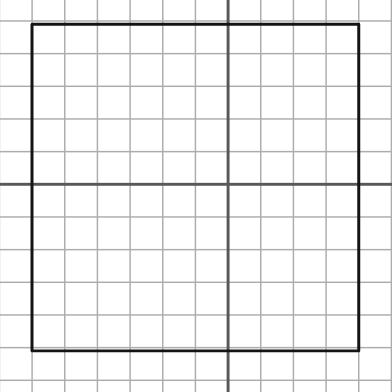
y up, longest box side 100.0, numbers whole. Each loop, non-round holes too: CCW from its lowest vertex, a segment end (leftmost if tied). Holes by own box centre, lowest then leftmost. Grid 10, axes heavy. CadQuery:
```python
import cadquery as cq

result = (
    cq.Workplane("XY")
    .moveTo(-60.0, -51.0)
    .lineTo(40.0, -51.0)
    .lineTo(40.0, 49.0)
    .lineTo(-60.0, 49.0)
    .close()
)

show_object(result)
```